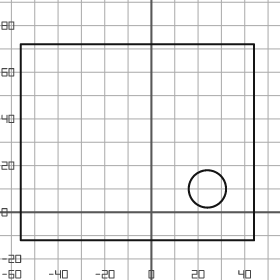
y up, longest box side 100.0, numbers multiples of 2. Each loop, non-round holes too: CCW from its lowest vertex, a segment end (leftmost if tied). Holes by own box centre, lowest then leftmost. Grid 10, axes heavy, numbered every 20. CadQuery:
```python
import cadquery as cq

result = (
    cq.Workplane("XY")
    .moveTo(-56.0, -12.0)
    .lineTo(44.0, -12.0)
    .lineTo(44.0, 72.0)
    .lineTo(-56.0, 72.0)
    .close()
    .moveTo(24.0, 10.0)
    .circle(8.0)
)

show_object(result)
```